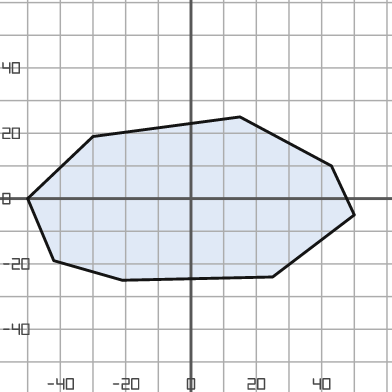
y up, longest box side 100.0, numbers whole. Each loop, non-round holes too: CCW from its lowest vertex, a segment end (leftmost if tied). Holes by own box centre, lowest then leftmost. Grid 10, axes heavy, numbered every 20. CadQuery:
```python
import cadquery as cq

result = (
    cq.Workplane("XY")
    .moveTo(-21.0, -25.0)
    .lineTo(25.0, -24.0)
    .lineTo(50.0, -5.0)
    .lineTo(43.0, 10.0)
    .lineTo(15.0, 25.0)
    .lineTo(-30.0, 19.0)
    .lineTo(-50.0, 0.0)
    .lineTo(-42.0, -19.0)
    .close()
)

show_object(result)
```